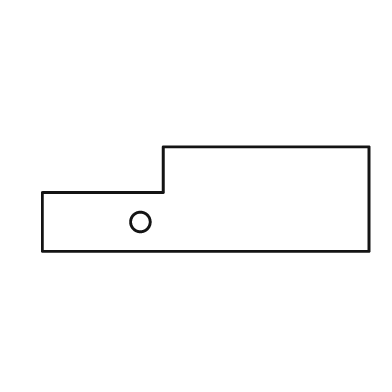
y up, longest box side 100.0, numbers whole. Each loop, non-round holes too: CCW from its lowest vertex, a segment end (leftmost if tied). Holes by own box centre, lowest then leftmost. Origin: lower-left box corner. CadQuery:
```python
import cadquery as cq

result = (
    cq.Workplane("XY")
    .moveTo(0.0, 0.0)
    .lineTo(100.0, 0.0)
    .lineTo(100.0, 32.0)
    .lineTo(37.0, 32.0)
    .lineTo(37.0, 18.0)
    .lineTo(0.0, 18.0)
    .close()
    .moveTo(30.0, 9.0)
    .circle(3.0)
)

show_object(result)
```